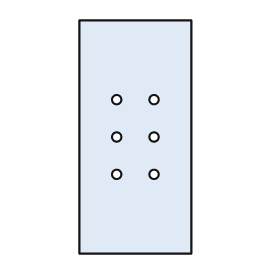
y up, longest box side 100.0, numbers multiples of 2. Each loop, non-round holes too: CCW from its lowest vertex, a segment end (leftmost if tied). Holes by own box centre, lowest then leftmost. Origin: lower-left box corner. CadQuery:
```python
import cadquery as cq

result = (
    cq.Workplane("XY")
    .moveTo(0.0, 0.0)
    .lineTo(48.0, 0.0)
    .lineTo(48.0, 100.0)
    .lineTo(0.0, 100.0)
    .close()
    .moveTo(16.0, 34.0)
    .circle(2.0)
    .moveTo(32.0, 34.0)
    .circle(2.0)
    .moveTo(16.0, 50.0)
    .circle(2.0)
    .moveTo(32.0, 50.0)
    .circle(2.0)
    .moveTo(16.0, 66.0)
    .circle(2.0)
    .moveTo(32.0, 66.0)
    .circle(2.0)
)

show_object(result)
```